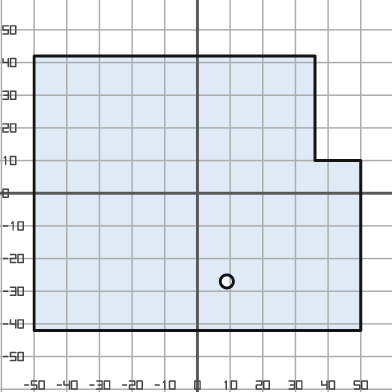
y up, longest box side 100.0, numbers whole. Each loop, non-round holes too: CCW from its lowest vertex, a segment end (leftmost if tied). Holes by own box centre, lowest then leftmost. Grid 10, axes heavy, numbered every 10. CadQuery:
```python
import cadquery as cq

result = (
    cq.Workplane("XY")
    .moveTo(-50.0, -42.0)
    .lineTo(50.0, -42.0)
    .lineTo(50.0, 10.0)
    .lineTo(36.0, 10.0)
    .lineTo(36.0, 42.0)
    .lineTo(-50.0, 42.0)
    .close()
    .moveTo(9.0, -27.0)
    .circle(2.0)
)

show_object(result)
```